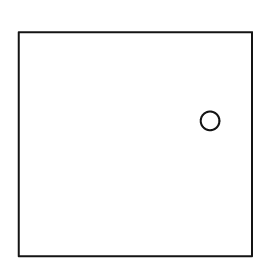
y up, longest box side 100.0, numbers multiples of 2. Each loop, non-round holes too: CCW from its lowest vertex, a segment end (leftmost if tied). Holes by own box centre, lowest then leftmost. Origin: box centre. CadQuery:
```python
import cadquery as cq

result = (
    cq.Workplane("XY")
    .moveTo(-50.0, -48.0)
    .lineTo(50.0, -48.0)
    .lineTo(50.0, 48.0)
    .lineTo(-50.0, 48.0)
    .close()
    .moveTo(32.0, 10.0)
    .circle(4.0)
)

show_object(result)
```